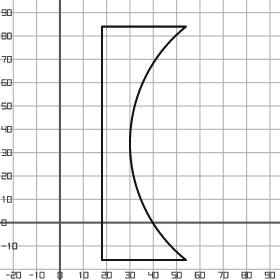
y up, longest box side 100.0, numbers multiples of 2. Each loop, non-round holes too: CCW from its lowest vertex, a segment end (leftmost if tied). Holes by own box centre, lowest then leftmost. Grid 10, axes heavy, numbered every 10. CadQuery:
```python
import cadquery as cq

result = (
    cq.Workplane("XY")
    .moveTo(18.0, -16.0)
    .lineTo(54.0, -16.0)
    .threePointArc((30.0, 34.0), (54.0, 84.0))
    .lineTo(18.0, 84.0)
    .close()
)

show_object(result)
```